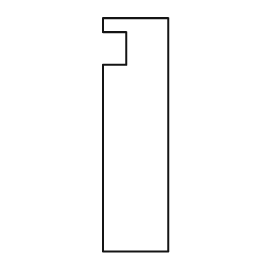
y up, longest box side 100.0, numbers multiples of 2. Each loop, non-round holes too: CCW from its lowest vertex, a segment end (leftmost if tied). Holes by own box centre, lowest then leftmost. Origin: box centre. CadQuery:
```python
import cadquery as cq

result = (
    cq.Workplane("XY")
    .moveTo(-14.0, -50.0)
    .lineTo(14.0, -50.0)
    .lineTo(14.0, 50.0)
    .lineTo(-14.0, 50.0)
    .lineTo(-14.0, 44.0)
    .lineTo(-4.0, 44.0)
    .lineTo(-4.0, 30.0)
    .lineTo(-14.0, 30.0)
    .close()
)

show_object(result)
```